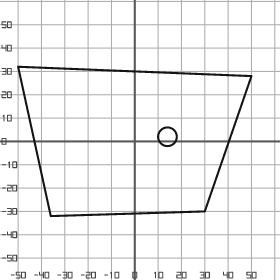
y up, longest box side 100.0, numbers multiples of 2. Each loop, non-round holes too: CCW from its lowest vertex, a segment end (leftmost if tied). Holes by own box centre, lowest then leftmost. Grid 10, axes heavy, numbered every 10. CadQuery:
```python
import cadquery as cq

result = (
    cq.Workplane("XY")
    .moveTo(-36.0, -32.0)
    .lineTo(30.0, -30.0)
    .lineTo(50.0, 28.0)
    .lineTo(-50.0, 32.0)
    .close()
    .moveTo(14.0, 2.0)
    .circle(4.0)
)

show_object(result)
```